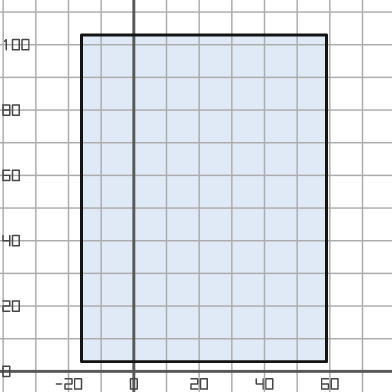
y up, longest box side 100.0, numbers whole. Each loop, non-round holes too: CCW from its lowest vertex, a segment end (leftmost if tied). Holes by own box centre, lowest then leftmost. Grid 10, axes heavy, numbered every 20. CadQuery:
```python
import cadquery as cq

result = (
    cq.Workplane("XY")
    .moveTo(-16.0, 3.0)
    .lineTo(59.0, 3.0)
    .lineTo(59.0, 103.0)
    .lineTo(-16.0, 103.0)
    .close()
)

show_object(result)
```